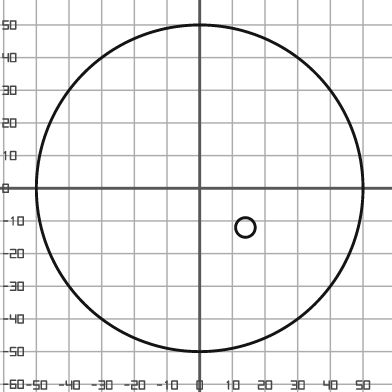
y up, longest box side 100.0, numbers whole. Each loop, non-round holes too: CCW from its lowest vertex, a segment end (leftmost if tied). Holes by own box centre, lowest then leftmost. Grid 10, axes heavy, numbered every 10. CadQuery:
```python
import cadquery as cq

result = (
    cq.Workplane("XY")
    .moveTo(0.0, 0.0)
    .circle(50.0)
    .moveTo(14.0, -12.0)
    .circle(3.0)
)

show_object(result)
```